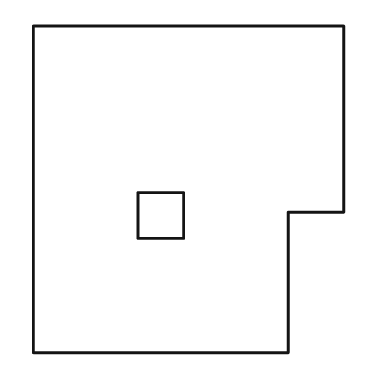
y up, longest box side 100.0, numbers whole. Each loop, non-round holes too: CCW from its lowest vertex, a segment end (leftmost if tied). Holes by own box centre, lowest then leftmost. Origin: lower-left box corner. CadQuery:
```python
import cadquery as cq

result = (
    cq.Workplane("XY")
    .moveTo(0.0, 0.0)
    .lineTo(78.0, 0.0)
    .lineTo(78.0, 43.0)
    .lineTo(95.0, 43.0)
    .lineTo(95.0, 100.0)
    .lineTo(0.0, 100.0)
    .close()
    .moveTo(32.0, 35.0)
    .lineTo(46.0, 35.0)
    .lineTo(46.0, 49.0)
    .lineTo(32.0, 49.0)
    .close()
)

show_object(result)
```